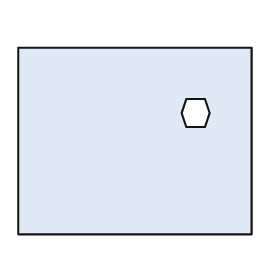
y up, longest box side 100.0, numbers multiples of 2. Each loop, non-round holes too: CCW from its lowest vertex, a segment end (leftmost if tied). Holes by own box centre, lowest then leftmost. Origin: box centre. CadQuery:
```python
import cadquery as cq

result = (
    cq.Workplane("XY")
    .moveTo(-50.0, -40.0)
    .lineTo(50.0, -40.0)
    .lineTo(50.0, 40.0)
    .lineTo(-50.0, 40.0)
    .close()
    .moveTo(22.0, 6.0)
    .lineTo(30.0, 6.0)
    .lineTo(32.0, 12.0)
    .lineTo(30.0, 18.0)
    .lineTo(22.0, 18.0)
    .lineTo(20.0, 12.0)
    .close()
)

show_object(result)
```